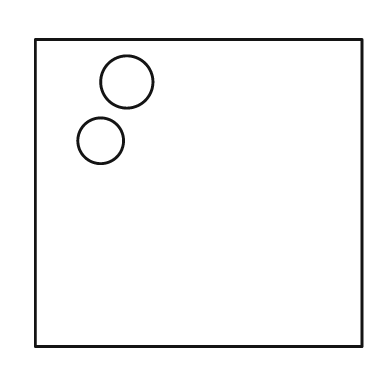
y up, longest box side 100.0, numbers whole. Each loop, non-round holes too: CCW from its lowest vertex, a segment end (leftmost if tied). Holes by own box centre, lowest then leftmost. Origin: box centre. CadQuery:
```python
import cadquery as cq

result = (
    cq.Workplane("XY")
    .moveTo(-50.0, -47.0)
    .lineTo(50.0, -47.0)
    .lineTo(50.0, 47.0)
    .lineTo(-50.0, 47.0)
    .close()
    .moveTo(-30.0, 16.0)
    .circle(7.0)
    .moveTo(-22.0, 34.0)
    .circle(8.0)
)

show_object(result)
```